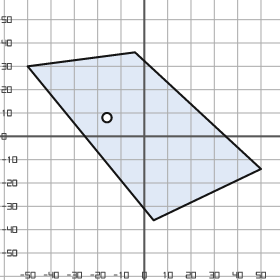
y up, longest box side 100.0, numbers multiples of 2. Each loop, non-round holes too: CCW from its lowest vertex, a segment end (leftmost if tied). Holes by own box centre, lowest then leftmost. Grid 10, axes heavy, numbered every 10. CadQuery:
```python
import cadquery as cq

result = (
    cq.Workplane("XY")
    .moveTo(4.0, -36.0)
    .lineTo(50.0, -14.0)
    .lineTo(-4.0, 36.0)
    .lineTo(-50.0, 30.0)
    .close()
    .moveTo(-16.0, 8.0)
    .circle(2.0)
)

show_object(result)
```